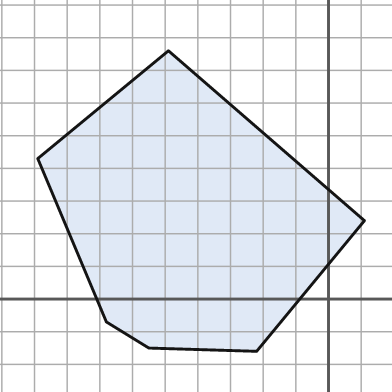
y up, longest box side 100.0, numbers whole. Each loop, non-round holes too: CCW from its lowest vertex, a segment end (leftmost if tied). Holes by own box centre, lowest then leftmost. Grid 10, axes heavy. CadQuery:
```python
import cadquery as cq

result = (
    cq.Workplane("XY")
    .moveTo(-22.0, -16.0)
    .lineTo(11.0, 24.0)
    .lineTo(-49.0, 76.0)
    .lineTo(-89.0, 43.0)
    .lineTo(-68.0, -7.0)
    .lineTo(-55.0, -15.0)
    .close()
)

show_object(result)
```